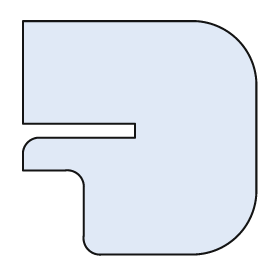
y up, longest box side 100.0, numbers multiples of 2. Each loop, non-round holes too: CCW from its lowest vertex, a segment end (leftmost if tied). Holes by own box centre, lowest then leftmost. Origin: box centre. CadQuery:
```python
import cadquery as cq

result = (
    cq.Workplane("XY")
    .moveTo(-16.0, -50.0)
    .lineTo(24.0, -50.0)
    .threePointArc((42.0, -42.0), (50.0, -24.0))
    .lineTo(50.0, 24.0)
    .threePointArc((42.0, 42.0), (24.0, 50.0))
    .lineTo(-50.0, 50.0)
    .lineTo(-50.0, 6.0)
    .lineTo(-2.0, 6.0)
    .lineTo(-2.0, 0.0)
    .lineTo(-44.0, 0.0)
    .threePointArc((-48.0, -2.0), (-50.0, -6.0))
    .lineTo(-50.0, -14.0)
    .lineTo(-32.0, -14.0)
    .threePointArc((-26.0, -16.0), (-24.0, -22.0))
    .lineTo(-24.0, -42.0)
    .threePointArc((-22.0, -48.0), (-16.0, -50.0))
    .close()
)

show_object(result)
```